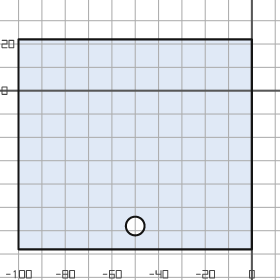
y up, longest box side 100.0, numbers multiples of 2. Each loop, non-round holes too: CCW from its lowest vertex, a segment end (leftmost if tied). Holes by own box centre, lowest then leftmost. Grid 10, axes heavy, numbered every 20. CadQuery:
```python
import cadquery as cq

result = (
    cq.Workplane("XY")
    .moveTo(-100.0, -68.0)
    .lineTo(0.0, -68.0)
    .lineTo(0.0, 22.0)
    .lineTo(-100.0, 22.0)
    .close()
    .moveTo(-50.0, -58.0)
    .circle(4.0)
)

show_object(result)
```